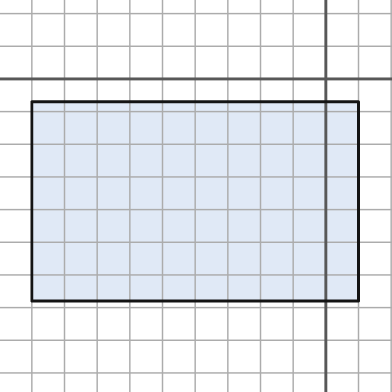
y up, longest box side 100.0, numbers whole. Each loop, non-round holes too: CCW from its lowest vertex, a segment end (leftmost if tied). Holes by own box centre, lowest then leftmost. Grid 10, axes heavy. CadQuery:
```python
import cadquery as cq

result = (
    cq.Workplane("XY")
    .moveTo(-90.0, -68.0)
    .lineTo(10.0, -68.0)
    .lineTo(10.0, -7.0)
    .lineTo(-90.0, -7.0)
    .close()
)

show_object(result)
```